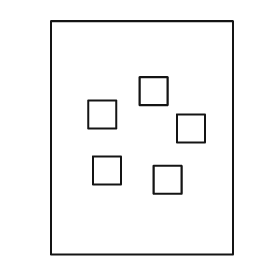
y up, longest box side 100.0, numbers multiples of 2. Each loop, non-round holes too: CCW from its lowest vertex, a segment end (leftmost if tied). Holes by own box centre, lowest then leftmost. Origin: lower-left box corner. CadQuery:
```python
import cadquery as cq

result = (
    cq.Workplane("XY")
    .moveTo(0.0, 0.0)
    .lineTo(78.0, 0.0)
    .lineTo(78.0, 100.0)
    .lineTo(0.0, 100.0)
    .close()
    .moveTo(44.0, 26.0)
    .lineTo(56.0, 26.0)
    .lineTo(56.0, 38.0)
    .lineTo(44.0, 38.0)
    .close()
    .moveTo(18.0, 30.0)
    .lineTo(30.0, 30.0)
    .lineTo(30.0, 42.0)
    .lineTo(18.0, 42.0)
    .close()
    .moveTo(54.0, 48.0)
    .lineTo(66.0, 48.0)
    .lineTo(66.0, 60.0)
    .lineTo(54.0, 60.0)
    .close()
    .moveTo(16.0, 54.0)
    .lineTo(28.0, 54.0)
    .lineTo(28.0, 66.0)
    .lineTo(16.0, 66.0)
    .close()
    .moveTo(38.0, 64.0)
    .lineTo(50.0, 64.0)
    .lineTo(50.0, 76.0)
    .lineTo(38.0, 76.0)
    .close()
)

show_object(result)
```